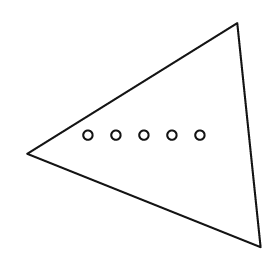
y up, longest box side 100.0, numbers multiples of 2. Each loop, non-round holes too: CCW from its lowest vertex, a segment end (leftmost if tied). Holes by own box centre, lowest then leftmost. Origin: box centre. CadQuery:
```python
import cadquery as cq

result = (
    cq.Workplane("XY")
    .moveTo(50.0, -48.0)
    .lineTo(40.0, 48.0)
    .lineTo(-50.0, -8.0)
    .close()
    .moveTo(-24.0, 0.0)
    .circle(2.0)
    .moveTo(-12.0, 0.0)
    .circle(2.0)
    .moveTo(0.0, 0.0)
    .circle(2.0)
    .moveTo(12.0, 0.0)
    .circle(2.0)
    .moveTo(24.0, 0.0)
    .circle(2.0)
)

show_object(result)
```